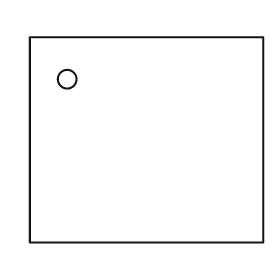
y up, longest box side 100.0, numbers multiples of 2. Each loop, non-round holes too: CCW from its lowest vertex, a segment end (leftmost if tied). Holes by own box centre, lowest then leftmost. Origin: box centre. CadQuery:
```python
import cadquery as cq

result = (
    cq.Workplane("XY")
    .moveTo(-50.0, -44.0)
    .lineTo(50.0, -44.0)
    .lineTo(50.0, 44.0)
    .lineTo(-50.0, 44.0)
    .close()
    .moveTo(-34.0, 26.0)
    .circle(4.0)
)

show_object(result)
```